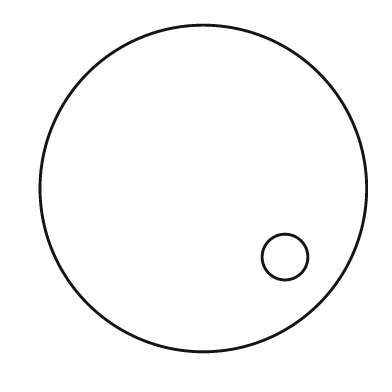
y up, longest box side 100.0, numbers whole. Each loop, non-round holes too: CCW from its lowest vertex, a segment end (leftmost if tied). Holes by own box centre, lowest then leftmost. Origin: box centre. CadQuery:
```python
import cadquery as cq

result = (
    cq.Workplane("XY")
    .moveTo(0.0, 0.0)
    .circle(50.0)
    .moveTo(25.0, -21.0)
    .circle(7.0)
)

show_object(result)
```